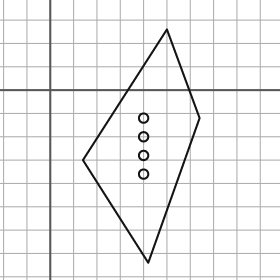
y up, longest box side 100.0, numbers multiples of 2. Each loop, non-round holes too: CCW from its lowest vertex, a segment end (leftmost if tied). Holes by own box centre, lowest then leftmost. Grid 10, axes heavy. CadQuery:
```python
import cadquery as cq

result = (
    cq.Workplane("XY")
    .moveTo(42.0, -74.0)
    .lineTo(64.0, -12.0)
    .lineTo(50.0, 26.0)
    .lineTo(14.0, -30.0)
    .close()
    .moveTo(40.0, -36.0)
    .circle(2.0)
    .moveTo(40.0, -28.0)
    .circle(2.0)
    .moveTo(40.0, -20.0)
    .circle(2.0)
    .moveTo(40.0, -12.0)
    .circle(2.0)
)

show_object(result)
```